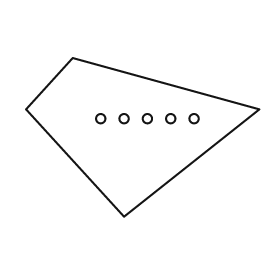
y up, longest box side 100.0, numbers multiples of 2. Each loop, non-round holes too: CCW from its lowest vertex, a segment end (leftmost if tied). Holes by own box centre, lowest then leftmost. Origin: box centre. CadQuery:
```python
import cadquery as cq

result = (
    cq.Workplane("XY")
    .moveTo(-8.0, -34.0)
    .lineTo(50.0, 12.0)
    .lineTo(-30.0, 34.0)
    .lineTo(-50.0, 12.0)
    .close()
    .moveTo(-18.0, 8.0)
    .circle(2.0)
    .moveTo(-8.0, 8.0)
    .circle(2.0)
    .moveTo(2.0, 8.0)
    .circle(2.0)
    .moveTo(12.0, 8.0)
    .circle(2.0)
    .moveTo(22.0, 8.0)
    .circle(2.0)
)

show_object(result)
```